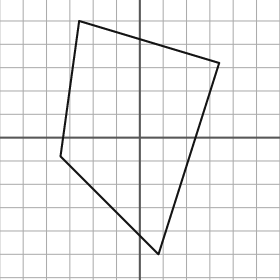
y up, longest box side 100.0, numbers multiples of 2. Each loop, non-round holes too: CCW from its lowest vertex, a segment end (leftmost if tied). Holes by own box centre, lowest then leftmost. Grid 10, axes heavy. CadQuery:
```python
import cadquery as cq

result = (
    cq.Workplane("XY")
    .moveTo(8.0, -50.0)
    .lineTo(34.0, 32.0)
    .lineTo(-26.0, 50.0)
    .lineTo(-34.0, -8.0)
    .close()
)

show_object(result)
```